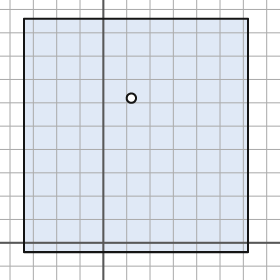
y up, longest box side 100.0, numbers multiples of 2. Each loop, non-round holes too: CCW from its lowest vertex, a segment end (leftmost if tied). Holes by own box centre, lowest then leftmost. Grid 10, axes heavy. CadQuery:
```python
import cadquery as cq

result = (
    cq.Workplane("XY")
    .moveTo(-34.0, -4.0)
    .lineTo(62.0, -4.0)
    .lineTo(62.0, 96.0)
    .lineTo(-34.0, 96.0)
    .close()
    .moveTo(12.0, 62.0)
    .circle(2.0)
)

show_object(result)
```